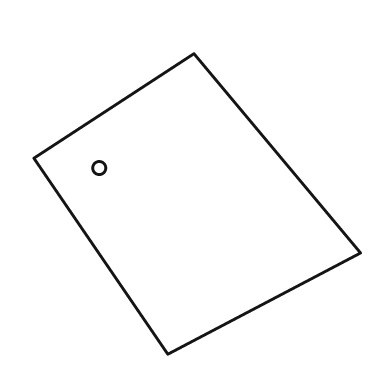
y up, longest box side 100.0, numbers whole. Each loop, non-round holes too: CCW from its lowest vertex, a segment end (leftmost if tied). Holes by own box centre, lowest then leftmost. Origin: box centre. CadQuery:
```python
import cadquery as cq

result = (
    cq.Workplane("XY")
    .moveTo(-9.0, -46.0)
    .lineTo(50.0, -15.0)
    .lineTo(-1.0, 46.0)
    .lineTo(-50.0, 14.0)
    .close()
    .moveTo(-30.0, 11.0)
    .circle(2.0)
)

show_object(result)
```